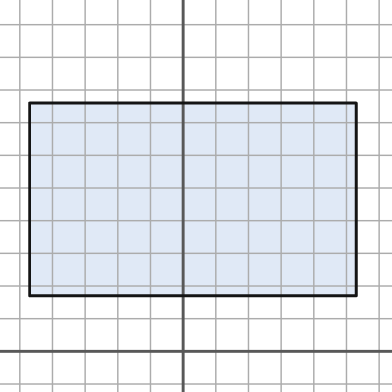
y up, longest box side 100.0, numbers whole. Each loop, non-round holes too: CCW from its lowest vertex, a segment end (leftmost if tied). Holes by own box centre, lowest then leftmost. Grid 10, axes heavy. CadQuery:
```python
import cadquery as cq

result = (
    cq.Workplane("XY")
    .moveTo(-47.0, 17.0)
    .lineTo(53.0, 17.0)
    .lineTo(53.0, 76.0)
    .lineTo(-47.0, 76.0)
    .close()
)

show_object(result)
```